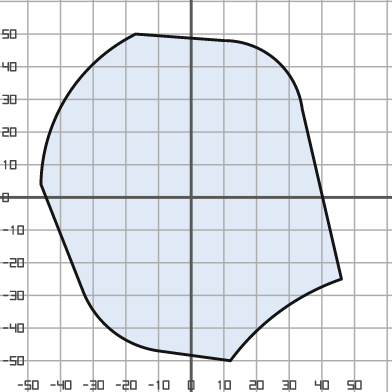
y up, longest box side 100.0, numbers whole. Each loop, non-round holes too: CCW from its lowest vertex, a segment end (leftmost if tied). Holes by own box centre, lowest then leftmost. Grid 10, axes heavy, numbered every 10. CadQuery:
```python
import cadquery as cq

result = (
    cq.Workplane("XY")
    .moveTo(12.0, -50.0)
    .threePointArc((27.0, -35.0), (46.0, -25.0))
    .lineTo(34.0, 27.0)
    .threePointArc((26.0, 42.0), (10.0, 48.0))
    .lineTo(-17.0, 50.0)
    .threePointArc((-38.0, 31.0), (-46.0, 4.0))
    .lineTo(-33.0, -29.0)
    .threePointArc((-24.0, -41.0), (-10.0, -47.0))
    .close()
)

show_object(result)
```